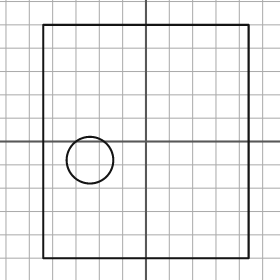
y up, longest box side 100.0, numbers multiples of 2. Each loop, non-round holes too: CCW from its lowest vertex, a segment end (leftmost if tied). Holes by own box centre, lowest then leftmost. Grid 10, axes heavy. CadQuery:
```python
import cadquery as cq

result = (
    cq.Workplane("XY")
    .moveTo(-44.0, -50.0)
    .lineTo(44.0, -50.0)
    .lineTo(44.0, 50.0)
    .lineTo(-44.0, 50.0)
    .close()
    .moveTo(-24.0, -8.0)
    .circle(10.0)
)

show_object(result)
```